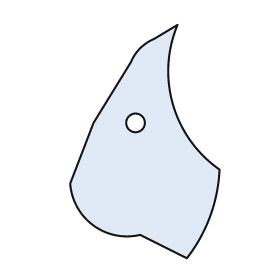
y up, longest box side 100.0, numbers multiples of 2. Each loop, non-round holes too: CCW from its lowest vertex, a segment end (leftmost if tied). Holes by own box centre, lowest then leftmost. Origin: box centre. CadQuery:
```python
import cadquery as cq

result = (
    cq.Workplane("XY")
    .moveTo(18.0, -50.0)
    .threePointArc((28.0, -32.0), (32.0, -12.0))
    .threePointArc((12.0, 16.0), (14.0, 50.0))
    .lineTo(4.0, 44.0)
    .threePointArc((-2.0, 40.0), (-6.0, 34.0))
    .lineTo(-22.0, 8.0)
    .lineTo(-32.0, -18.0)
    .threePointArc((-22.0, -36.0), (-2.0, -40.0))
    .close()
    .moveTo(-4.0, 8.0)
    .circle(4.0)
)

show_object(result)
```